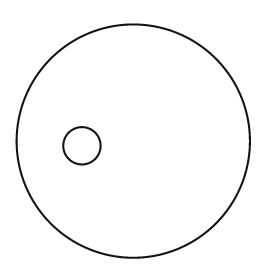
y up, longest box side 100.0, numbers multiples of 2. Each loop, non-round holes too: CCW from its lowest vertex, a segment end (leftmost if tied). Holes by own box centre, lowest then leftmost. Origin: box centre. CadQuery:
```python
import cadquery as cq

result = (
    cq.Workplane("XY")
    .moveTo(0.0, 0.0)
    .circle(50.0)
    .moveTo(-22.0, -2.0)
    .circle(8.0)
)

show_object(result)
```